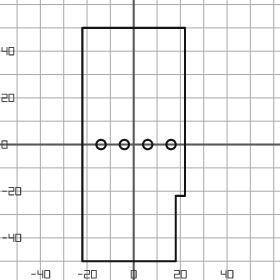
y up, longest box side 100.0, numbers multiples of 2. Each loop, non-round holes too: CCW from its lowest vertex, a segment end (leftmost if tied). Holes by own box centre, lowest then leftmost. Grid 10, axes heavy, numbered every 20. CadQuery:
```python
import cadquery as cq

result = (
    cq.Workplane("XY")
    .moveTo(-22.0, -50.0)
    .lineTo(18.0, -50.0)
    .lineTo(18.0, -22.0)
    .lineTo(22.0, -22.0)
    .lineTo(22.0, 50.0)
    .lineTo(-22.0, 50.0)
    .close()
    .moveTo(-14.0, 0.0)
    .circle(2.0)
    .moveTo(-4.0, 0.0)
    .circle(2.0)
    .moveTo(6.0, 0.0)
    .circle(2.0)
    .moveTo(16.0, 0.0)
    .circle(2.0)
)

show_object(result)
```